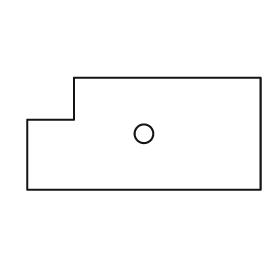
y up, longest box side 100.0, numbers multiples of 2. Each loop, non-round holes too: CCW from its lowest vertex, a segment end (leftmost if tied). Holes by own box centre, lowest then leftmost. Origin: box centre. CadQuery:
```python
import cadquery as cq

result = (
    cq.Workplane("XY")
    .moveTo(-50.0, -24.0)
    .lineTo(50.0, -24.0)
    .lineTo(50.0, 24.0)
    .lineTo(-30.0, 24.0)
    .lineTo(-30.0, 6.0)
    .lineTo(-50.0, 6.0)
    .close()
    .moveTo(0.0, 0.0)
    .circle(4.0)
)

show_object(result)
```